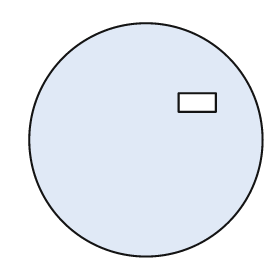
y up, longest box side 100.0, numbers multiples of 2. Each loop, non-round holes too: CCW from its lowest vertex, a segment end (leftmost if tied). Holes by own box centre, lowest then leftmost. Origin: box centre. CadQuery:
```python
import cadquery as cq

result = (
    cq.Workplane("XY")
    .moveTo(0.0, 0.0)
    .circle(50.0)
    .moveTo(14.0, 12.0)
    .lineTo(30.0, 12.0)
    .lineTo(30.0, 20.0)
    .lineTo(14.0, 20.0)
    .close()
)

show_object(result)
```